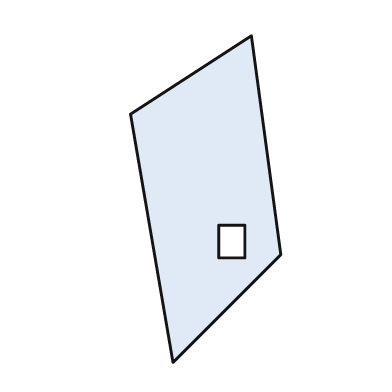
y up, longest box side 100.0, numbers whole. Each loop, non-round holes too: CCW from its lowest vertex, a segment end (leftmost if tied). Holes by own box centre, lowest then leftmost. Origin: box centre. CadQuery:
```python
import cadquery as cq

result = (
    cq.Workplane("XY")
    .moveTo(-10.0, -50.0)
    .lineTo(23.0, -17.0)
    .lineTo(14.0, 50.0)
    .lineTo(-23.0, 26.0)
    .close()
    .moveTo(4.0, -18.0)
    .lineTo(12.0, -18.0)
    .lineTo(12.0, -8.0)
    .lineTo(4.0, -8.0)
    .close()
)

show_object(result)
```